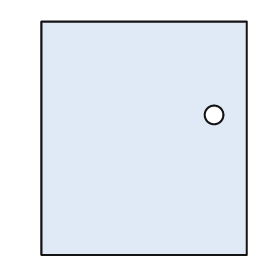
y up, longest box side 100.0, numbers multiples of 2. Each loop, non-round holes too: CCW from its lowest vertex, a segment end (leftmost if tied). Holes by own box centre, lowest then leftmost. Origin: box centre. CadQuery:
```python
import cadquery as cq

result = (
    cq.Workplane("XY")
    .moveTo(-44.0, -50.0)
    .lineTo(44.0, -50.0)
    .lineTo(44.0, 50.0)
    .lineTo(-44.0, 50.0)
    .close()
    .moveTo(30.0, 10.0)
    .circle(4.0)
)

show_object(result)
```